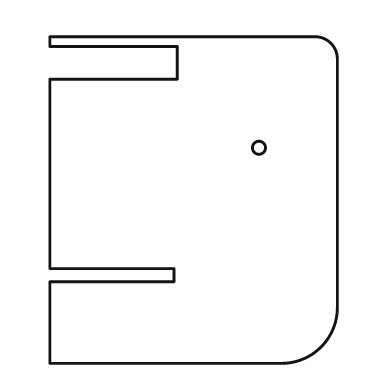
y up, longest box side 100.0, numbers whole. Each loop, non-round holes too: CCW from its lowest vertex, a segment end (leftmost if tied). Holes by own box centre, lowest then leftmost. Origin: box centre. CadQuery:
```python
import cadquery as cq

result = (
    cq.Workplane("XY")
    .moveTo(-44.0, -50.0)
    .lineTo(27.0, -50.0)
    .threePointArc((39.0, -45.0), (44.0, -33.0))
    .lineTo(44.0, 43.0)
    .threePointArc((42.0, 48.0), (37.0, 50.0))
    .lineTo(-44.0, 50.0)
    .lineTo(-44.0, 47.0)
    .lineTo(-5.0, 47.0)
    .lineTo(-5.0, 37.0)
    .lineTo(-44.0, 37.0)
    .lineTo(-44.0, -21.0)
    .lineTo(-6.0, -21.0)
    .lineTo(-6.0, -25.0)
    .lineTo(-44.0, -25.0)
    .close()
    .moveTo(20.0, 16.0)
    .circle(2.0)
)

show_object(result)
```